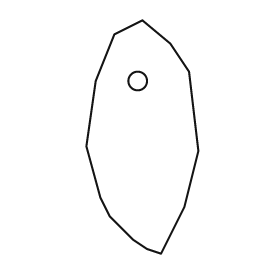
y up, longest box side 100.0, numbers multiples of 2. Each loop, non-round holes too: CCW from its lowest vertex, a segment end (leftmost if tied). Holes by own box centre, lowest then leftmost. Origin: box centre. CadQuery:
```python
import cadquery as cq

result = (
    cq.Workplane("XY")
    .moveTo(8.0, -50.0)
    .lineTo(18.0, -30.0)
    .lineTo(24.0, -6.0)
    .lineTo(20.0, 28.0)
    .lineTo(12.0, 40.0)
    .lineTo(0.0, 50.0)
    .lineTo(-12.0, 44.0)
    .lineTo(-20.0, 24.0)
    .lineTo(-24.0, -4.0)
    .lineTo(-18.0, -26.0)
    .lineTo(-14.0, -34.0)
    .lineTo(-4.0, -44.0)
    .lineTo(2.0, -48.0)
    .close()
    .moveTo(-2.0, 24.0)
    .circle(4.0)
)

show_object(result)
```